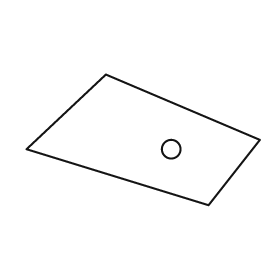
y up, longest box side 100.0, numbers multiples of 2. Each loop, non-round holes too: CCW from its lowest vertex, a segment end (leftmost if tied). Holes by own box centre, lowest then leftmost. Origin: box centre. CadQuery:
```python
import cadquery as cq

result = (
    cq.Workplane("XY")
    .moveTo(28.0, -28.0)
    .lineTo(50.0, 0.0)
    .lineTo(-16.0, 28.0)
    .lineTo(-50.0, -4.0)
    .close()
    .moveTo(12.0, -4.0)
    .circle(4.0)
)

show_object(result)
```